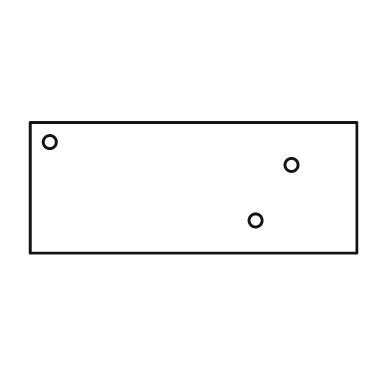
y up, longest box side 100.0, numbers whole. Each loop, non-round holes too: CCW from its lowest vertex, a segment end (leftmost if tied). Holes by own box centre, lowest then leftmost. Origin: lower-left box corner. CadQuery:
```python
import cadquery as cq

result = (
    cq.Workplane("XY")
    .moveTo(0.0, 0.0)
    .lineTo(100.0, 0.0)
    .lineTo(100.0, 40.0)
    .lineTo(0.0, 40.0)
    .close()
    .moveTo(69.0, 10.0)
    .circle(2.0)
    .moveTo(80.0, 27.0)
    .circle(2.0)
    .moveTo(6.0, 34.0)
    .circle(2.0)
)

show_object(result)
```